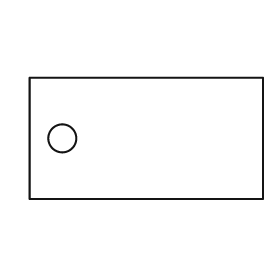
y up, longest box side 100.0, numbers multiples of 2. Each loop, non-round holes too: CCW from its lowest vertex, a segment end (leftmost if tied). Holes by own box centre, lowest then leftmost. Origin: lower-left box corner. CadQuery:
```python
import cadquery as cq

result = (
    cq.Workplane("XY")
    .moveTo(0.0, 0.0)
    .lineTo(100.0, 0.0)
    .lineTo(100.0, 52.0)
    .lineTo(0.0, 52.0)
    .close()
    .moveTo(14.0, 26.0)
    .circle(6.0)
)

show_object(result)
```